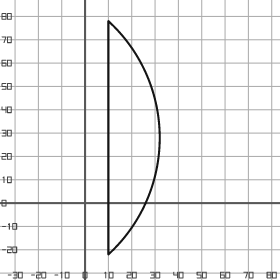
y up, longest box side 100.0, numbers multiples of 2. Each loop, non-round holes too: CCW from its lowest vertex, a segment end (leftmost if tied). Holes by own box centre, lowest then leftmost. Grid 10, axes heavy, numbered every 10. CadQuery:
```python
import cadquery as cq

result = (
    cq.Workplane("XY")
    .moveTo(10.0, -22.0)
    .threePointArc((32.0, 28.0), (10.0, 78.0))
    .close()
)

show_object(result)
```